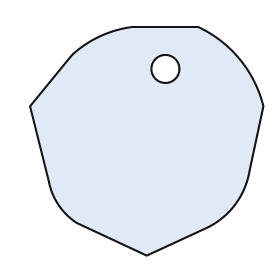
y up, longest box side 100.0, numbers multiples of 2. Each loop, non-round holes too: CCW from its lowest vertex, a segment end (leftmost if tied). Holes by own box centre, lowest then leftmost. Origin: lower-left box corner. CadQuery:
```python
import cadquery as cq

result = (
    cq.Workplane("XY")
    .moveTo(50.0, 0.0)
    .lineTo(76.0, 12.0)
    .threePointArc((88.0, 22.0), (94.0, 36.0))
    .lineTo(100.0, 64.0)
    .threePointArc((90.0, 84.0), (72.0, 98.0))
    .lineTo(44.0, 98.0)
    .threePointArc((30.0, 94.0), (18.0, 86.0))
    .lineTo(0.0, 64.0)
    .lineTo(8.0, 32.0)
    .threePointArc((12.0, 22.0), (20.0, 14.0))
    .close()
    .moveTo(58.0, 80.0)
    .circle(6.0)
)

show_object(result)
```